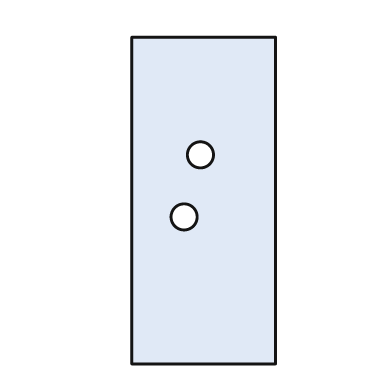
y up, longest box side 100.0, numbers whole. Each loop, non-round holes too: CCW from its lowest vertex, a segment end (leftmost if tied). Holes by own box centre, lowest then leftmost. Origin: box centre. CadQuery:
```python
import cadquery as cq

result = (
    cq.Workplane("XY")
    .moveTo(-22.0, -50.0)
    .lineTo(22.0, -50.0)
    .lineTo(22.0, 50.0)
    .lineTo(-22.0, 50.0)
    .close()
    .moveTo(-6.0, -5.0)
    .circle(4.0)
    .moveTo(-1.0, 14.0)
    .circle(4.0)
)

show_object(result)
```